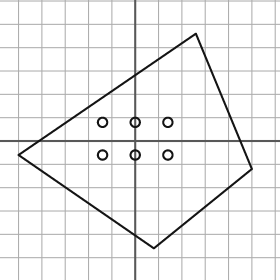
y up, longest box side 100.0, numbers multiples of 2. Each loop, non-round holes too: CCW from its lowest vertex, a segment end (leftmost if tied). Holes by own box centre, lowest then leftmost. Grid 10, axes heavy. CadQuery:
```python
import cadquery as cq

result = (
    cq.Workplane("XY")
    .moveTo(8.0, -46.0)
    .lineTo(50.0, -12.0)
    .lineTo(26.0, 46.0)
    .lineTo(-50.0, -6.0)
    .close()
    .moveTo(-14.0, -6.0)
    .circle(2.0)
    .moveTo(0.0, -6.0)
    .circle(2.0)
    .moveTo(14.0, -6.0)
    .circle(2.0)
    .moveTo(-14.0, 8.0)
    .circle(2.0)
    .moveTo(0.0, 8.0)
    .circle(2.0)
    .moveTo(14.0, 8.0)
    .circle(2.0)
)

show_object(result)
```